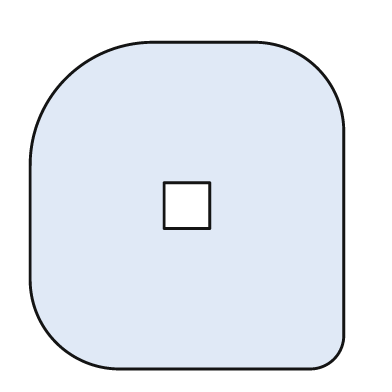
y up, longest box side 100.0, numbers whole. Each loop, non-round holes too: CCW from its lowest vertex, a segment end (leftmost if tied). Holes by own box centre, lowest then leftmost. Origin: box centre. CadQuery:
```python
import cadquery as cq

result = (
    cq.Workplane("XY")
    .moveTo(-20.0, -50.0)
    .lineTo(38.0, -50.0)
    .threePointArc((45.0, -47.0), (48.0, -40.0))
    .lineTo(48.0, 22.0)
    .threePointArc((40.0, 42.0), (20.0, 50.0))
    .lineTo(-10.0, 50.0)
    .threePointArc((-37.0, 39.0), (-48.0, 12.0))
    .lineTo(-48.0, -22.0)
    .threePointArc((-40.0, -42.0), (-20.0, -50.0))
    .close()
    .moveTo(-7.0, -7.0)
    .lineTo(7.0, -7.0)
    .lineTo(7.0, 7.0)
    .lineTo(-7.0, 7.0)
    .close()
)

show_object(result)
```